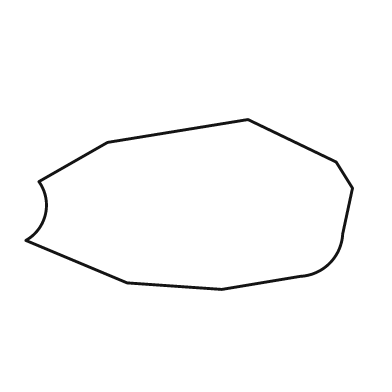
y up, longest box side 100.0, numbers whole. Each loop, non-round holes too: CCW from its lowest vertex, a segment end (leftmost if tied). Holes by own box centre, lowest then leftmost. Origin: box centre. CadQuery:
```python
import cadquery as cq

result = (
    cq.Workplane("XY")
    .moveTo(10.0, -26.0)
    .lineTo(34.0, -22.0)
    .threePointArc((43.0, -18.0), (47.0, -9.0))
    .lineTo(50.0, 5.0)
    .lineTo(45.0, 13.0)
    .lineTo(18.0, 26.0)
    .lineTo(-25.0, 19.0)
    .lineTo(-46.0, 7.0)
    .threePointArc((-44.0, -3.0), (-50.0, -11.0))
    .lineTo(-19.0, -24.0)
    .close()
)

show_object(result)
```